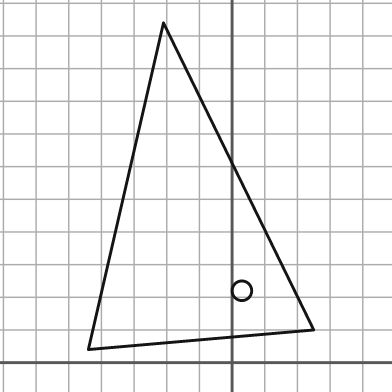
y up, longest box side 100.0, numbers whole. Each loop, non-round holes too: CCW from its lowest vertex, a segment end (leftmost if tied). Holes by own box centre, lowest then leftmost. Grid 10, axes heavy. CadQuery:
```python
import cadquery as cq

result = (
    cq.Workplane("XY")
    .moveTo(-44.0, 4.0)
    .lineTo(25.0, 10.0)
    .lineTo(-21.0, 104.0)
    .close()
    .moveTo(3.0, 22.0)
    .circle(3.0)
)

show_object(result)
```